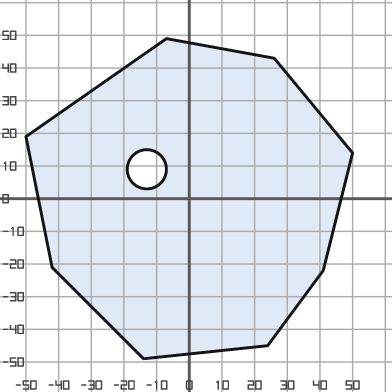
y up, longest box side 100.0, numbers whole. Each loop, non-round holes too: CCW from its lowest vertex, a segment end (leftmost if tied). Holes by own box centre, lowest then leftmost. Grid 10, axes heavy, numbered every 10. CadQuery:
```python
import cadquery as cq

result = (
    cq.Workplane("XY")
    .moveTo(-14.0, -49.0)
    .lineTo(24.0, -45.0)
    .lineTo(41.0, -22.0)
    .lineTo(50.0, 14.0)
    .lineTo(26.0, 43.0)
    .lineTo(-7.0, 49.0)
    .lineTo(-50.0, 19.0)
    .lineTo(-42.0, -21.0)
    .close()
    .moveTo(-13.0, 9.0)
    .circle(6.0)
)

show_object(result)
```